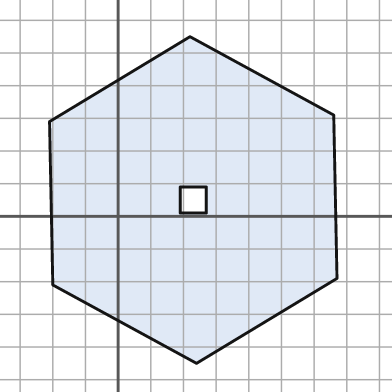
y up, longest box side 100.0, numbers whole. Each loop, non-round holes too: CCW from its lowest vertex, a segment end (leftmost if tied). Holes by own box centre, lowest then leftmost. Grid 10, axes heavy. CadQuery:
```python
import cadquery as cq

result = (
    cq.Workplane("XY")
    .moveTo(24.0, -45.0)
    .lineTo(67.0, -19.0)
    .lineTo(66.0, 31.0)
    .lineTo(22.0, 55.0)
    .lineTo(-21.0, 29.0)
    .lineTo(-20.0, -21.0)
    .close()
    .moveTo(19.0, 1.0)
    .lineTo(27.0, 1.0)
    .lineTo(27.0, 9.0)
    .lineTo(19.0, 9.0)
    .close()
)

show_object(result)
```